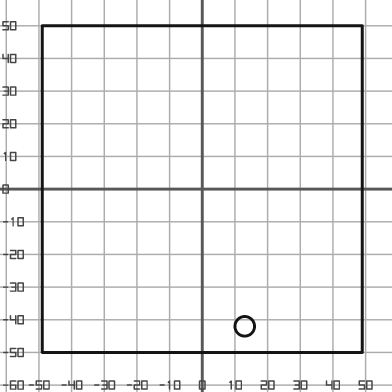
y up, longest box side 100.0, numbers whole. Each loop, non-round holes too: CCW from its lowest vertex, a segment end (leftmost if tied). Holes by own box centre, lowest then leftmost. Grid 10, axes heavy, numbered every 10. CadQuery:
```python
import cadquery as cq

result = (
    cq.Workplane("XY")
    .moveTo(-49.0, -50.0)
    .lineTo(49.0, -50.0)
    .lineTo(49.0, 50.0)
    .lineTo(-49.0, 50.0)
    .close()
    .moveTo(13.0, -42.0)
    .circle(3.0)
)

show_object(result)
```